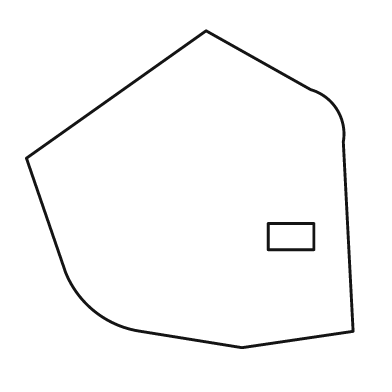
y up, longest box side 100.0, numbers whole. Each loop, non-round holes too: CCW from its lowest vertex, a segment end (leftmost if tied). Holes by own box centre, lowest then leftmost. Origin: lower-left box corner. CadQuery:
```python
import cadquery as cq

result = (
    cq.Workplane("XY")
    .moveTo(66.0, 0.0)
    .lineTo(100.0, 5.0)
    .lineTo(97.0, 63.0)
    .threePointArc((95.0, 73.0), (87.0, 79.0))
    .lineTo(55.0, 97.0)
    .lineTo(0.0, 58.0)
    .lineTo(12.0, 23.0)
    .threePointArc((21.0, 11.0), (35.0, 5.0))
    .close()
    .moveTo(74.0, 30.0)
    .lineTo(88.0, 30.0)
    .lineTo(88.0, 38.0)
    .lineTo(74.0, 38.0)
    .close()
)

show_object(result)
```